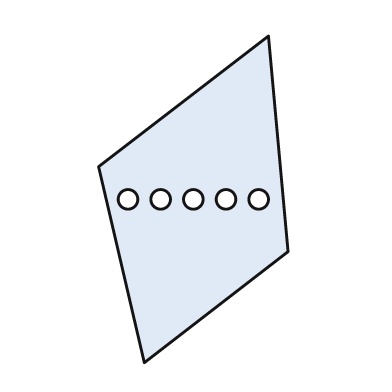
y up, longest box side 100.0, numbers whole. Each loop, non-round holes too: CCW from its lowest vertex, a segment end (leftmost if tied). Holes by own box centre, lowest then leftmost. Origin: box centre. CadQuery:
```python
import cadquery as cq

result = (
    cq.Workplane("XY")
    .moveTo(-15.0, -50.0)
    .lineTo(29.0, -16.0)
    .lineTo(23.0, 50.0)
    .lineTo(-29.0, 10.0)
    .close()
    .moveTo(-20.0, 0.0)
    .circle(3.0)
    .moveTo(-10.0, 0.0)
    .circle(3.0)
    .moveTo(0.0, 0.0)
    .circle(3.0)
    .moveTo(10.0, 0.0)
    .circle(3.0)
    .moveTo(20.0, 0.0)
    .circle(3.0)
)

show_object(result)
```